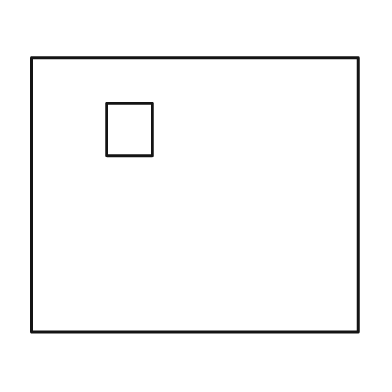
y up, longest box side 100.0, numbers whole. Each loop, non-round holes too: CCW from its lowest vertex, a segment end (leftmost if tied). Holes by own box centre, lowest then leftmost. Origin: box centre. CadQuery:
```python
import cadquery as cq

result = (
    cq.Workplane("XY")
    .moveTo(-50.0, -42.0)
    .lineTo(50.0, -42.0)
    .lineTo(50.0, 42.0)
    .lineTo(-50.0, 42.0)
    .close()
    .moveTo(-27.0, 12.0)
    .lineTo(-13.0, 12.0)
    .lineTo(-13.0, 28.0)
    .lineTo(-27.0, 28.0)
    .close()
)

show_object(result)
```